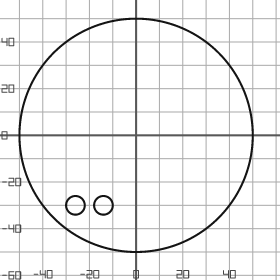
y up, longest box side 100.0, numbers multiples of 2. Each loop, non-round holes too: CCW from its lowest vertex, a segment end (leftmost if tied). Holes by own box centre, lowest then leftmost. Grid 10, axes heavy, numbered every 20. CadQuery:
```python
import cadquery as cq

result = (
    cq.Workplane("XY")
    .moveTo(0.0, 0.0)
    .circle(50.0)
    .moveTo(-26.0, -30.0)
    .circle(4.0)
    .moveTo(-14.0, -30.0)
    .circle(4.0)
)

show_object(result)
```